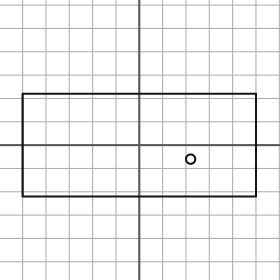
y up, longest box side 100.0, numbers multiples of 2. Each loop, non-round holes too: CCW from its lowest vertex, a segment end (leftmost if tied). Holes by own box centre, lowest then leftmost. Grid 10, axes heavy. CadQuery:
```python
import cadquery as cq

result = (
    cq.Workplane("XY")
    .moveTo(-50.0, -22.0)
    .lineTo(50.0, -22.0)
    .lineTo(50.0, 22.0)
    .lineTo(-50.0, 22.0)
    .close()
    .moveTo(22.0, -6.0)
    .circle(2.0)
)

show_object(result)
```